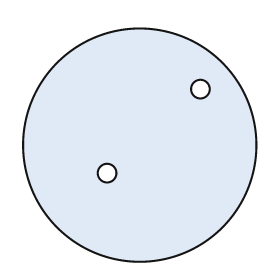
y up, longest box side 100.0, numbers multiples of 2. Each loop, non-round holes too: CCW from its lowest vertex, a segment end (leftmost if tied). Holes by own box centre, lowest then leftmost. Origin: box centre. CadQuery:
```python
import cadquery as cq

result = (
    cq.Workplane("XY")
    .moveTo(0.0, 0.0)
    .circle(50.0)
    .moveTo(-14.0, -12.0)
    .circle(4.0)
    .moveTo(26.0, 24.0)
    .circle(4.0)
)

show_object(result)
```